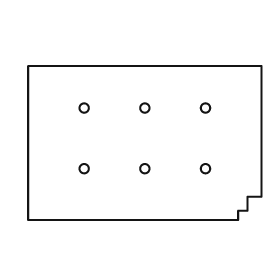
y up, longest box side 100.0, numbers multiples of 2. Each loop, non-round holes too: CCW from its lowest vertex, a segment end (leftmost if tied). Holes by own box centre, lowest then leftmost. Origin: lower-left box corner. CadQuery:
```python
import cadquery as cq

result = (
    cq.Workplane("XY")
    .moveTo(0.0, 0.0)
    .lineTo(90.0, 0.0)
    .lineTo(90.0, 4.0)
    .lineTo(94.0, 4.0)
    .lineTo(94.0, 10.0)
    .lineTo(100.0, 10.0)
    .lineTo(100.0, 66.0)
    .lineTo(0.0, 66.0)
    .close()
    .moveTo(24.0, 22.0)
    .circle(2.0)
    .moveTo(50.0, 22.0)
    .circle(2.0)
    .moveTo(76.0, 22.0)
    .circle(2.0)
    .moveTo(24.0, 48.0)
    .circle(2.0)
    .moveTo(50.0, 48.0)
    .circle(2.0)
    .moveTo(76.0, 48.0)
    .circle(2.0)
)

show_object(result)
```